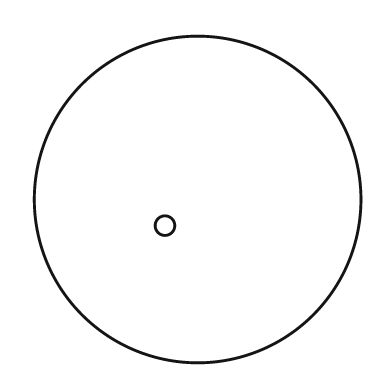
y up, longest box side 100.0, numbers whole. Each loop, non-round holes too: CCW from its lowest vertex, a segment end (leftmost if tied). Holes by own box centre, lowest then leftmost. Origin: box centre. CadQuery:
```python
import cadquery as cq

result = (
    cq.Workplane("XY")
    .moveTo(0.0, 0.0)
    .circle(50.0)
    .moveTo(-10.0, -8.0)
    .circle(3.0)
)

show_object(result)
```